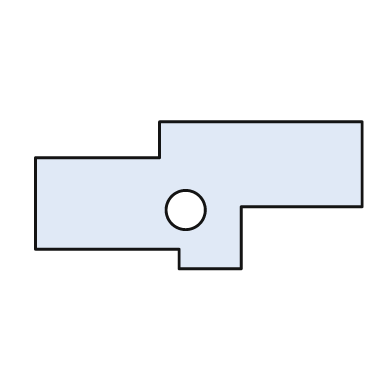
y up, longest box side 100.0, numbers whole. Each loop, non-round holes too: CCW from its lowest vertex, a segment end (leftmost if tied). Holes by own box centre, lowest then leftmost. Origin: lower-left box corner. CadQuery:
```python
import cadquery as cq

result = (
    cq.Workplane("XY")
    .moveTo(44.0, 0.0)
    .lineTo(63.0, 0.0)
    .lineTo(63.0, 19.0)
    .lineTo(100.0, 19.0)
    .lineTo(100.0, 45.0)
    .lineTo(38.0, 45.0)
    .lineTo(38.0, 34.0)
    .lineTo(0.0, 34.0)
    .lineTo(0.0, 6.0)
    .lineTo(44.0, 6.0)
    .close()
    .moveTo(46.0, 18.0)
    .circle(6.0)
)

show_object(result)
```